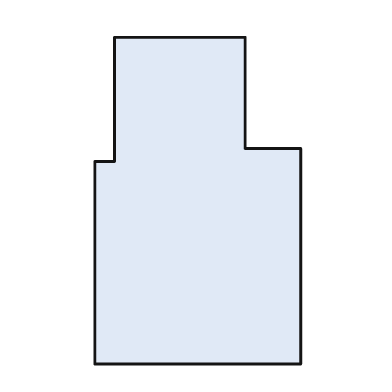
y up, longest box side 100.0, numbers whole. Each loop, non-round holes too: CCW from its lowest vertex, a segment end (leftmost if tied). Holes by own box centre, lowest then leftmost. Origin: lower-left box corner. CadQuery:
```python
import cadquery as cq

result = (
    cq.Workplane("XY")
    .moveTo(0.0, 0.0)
    .lineTo(63.0, 0.0)
    .lineTo(63.0, 66.0)
    .lineTo(46.0, 66.0)
    .lineTo(46.0, 100.0)
    .lineTo(6.0, 100.0)
    .lineTo(6.0, 62.0)
    .lineTo(0.0, 62.0)
    .close()
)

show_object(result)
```